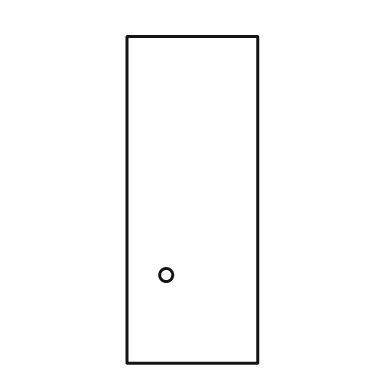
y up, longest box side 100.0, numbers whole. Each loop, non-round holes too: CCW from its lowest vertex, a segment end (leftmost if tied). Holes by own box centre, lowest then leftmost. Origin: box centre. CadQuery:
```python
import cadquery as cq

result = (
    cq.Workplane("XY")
    .moveTo(-20.0, -50.0)
    .lineTo(20.0, -50.0)
    .lineTo(20.0, 50.0)
    .lineTo(-20.0, 50.0)
    .close()
    .moveTo(-8.0, -23.0)
    .circle(2.0)
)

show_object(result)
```